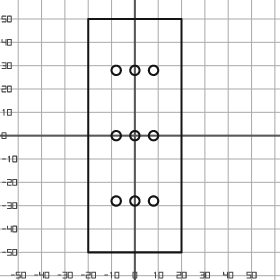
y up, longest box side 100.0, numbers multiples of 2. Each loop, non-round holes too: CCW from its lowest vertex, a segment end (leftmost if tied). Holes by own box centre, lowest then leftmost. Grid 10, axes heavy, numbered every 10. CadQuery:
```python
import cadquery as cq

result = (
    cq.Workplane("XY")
    .moveTo(-20.0, -50.0)
    .lineTo(20.0, -50.0)
    .lineTo(20.0, 50.0)
    .lineTo(-20.0, 50.0)
    .close()
    .moveTo(-8.0, -28.0)
    .circle(2.0)
    .moveTo(0.0, -28.0)
    .circle(2.0)
    .moveTo(8.0, -28.0)
    .circle(2.0)
    .moveTo(-8.0, 0.0)
    .circle(2.0)
    .moveTo(0.0, 0.0)
    .circle(2.0)
    .moveTo(8.0, 0.0)
    .circle(2.0)
    .moveTo(-8.0, 28.0)
    .circle(2.0)
    .moveTo(0.0, 28.0)
    .circle(2.0)
    .moveTo(8.0, 28.0)
    .circle(2.0)
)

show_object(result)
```